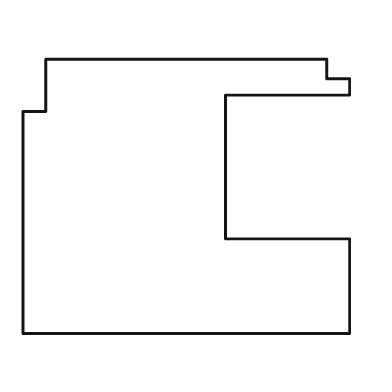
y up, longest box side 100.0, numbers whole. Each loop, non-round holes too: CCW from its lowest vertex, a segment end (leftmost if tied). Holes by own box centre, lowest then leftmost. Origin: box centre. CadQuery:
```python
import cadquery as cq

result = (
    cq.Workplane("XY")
    .moveTo(-50.0, -42.0)
    .lineTo(50.0, -42.0)
    .lineTo(50.0, -13.0)
    .lineTo(12.0, -13.0)
    .lineTo(12.0, 31.0)
    .lineTo(50.0, 31.0)
    .lineTo(50.0, 36.0)
    .lineTo(43.0, 36.0)
    .lineTo(43.0, 42.0)
    .lineTo(-43.0, 42.0)
    .lineTo(-43.0, 26.0)
    .lineTo(-50.0, 26.0)
    .close()
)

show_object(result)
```